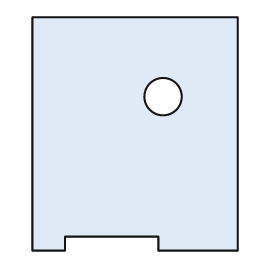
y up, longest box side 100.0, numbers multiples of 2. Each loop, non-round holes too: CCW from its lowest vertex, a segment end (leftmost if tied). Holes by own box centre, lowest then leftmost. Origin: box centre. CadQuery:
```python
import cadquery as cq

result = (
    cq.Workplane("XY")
    .moveTo(-44.0, -50.0)
    .lineTo(-30.0, -50.0)
    .lineTo(-30.0, -44.0)
    .lineTo(10.0, -44.0)
    .lineTo(10.0, -50.0)
    .lineTo(44.0, -50.0)
    .lineTo(44.0, 50.0)
    .lineTo(-44.0, 50.0)
    .close()
    .moveTo(12.0, 16.0)
    .circle(8.0)
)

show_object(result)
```